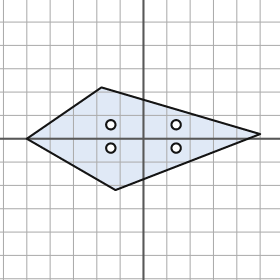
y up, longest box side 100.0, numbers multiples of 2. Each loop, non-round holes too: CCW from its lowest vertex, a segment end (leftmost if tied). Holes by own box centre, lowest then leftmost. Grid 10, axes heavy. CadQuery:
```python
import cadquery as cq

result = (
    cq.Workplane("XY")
    .moveTo(-12.0, -22.0)
    .lineTo(50.0, 2.0)
    .lineTo(-18.0, 22.0)
    .lineTo(-50.0, 0.0)
    .close()
    .moveTo(-14.0, -4.0)
    .circle(2.0)
    .moveTo(14.0, -4.0)
    .circle(2.0)
    .moveTo(-14.0, 6.0)
    .circle(2.0)
    .moveTo(14.0, 6.0)
    .circle(2.0)
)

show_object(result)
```